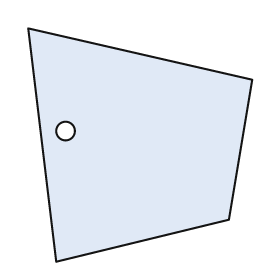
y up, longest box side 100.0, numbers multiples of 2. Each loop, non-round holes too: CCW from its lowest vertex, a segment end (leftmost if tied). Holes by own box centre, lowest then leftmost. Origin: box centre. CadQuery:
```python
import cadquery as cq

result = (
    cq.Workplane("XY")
    .moveTo(-36.0, -50.0)
    .lineTo(38.0, -32.0)
    .lineTo(48.0, 28.0)
    .lineTo(-48.0, 50.0)
    .close()
    .moveTo(-32.0, 6.0)
    .circle(4.0)
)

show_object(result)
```